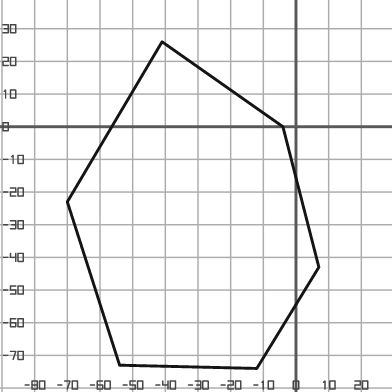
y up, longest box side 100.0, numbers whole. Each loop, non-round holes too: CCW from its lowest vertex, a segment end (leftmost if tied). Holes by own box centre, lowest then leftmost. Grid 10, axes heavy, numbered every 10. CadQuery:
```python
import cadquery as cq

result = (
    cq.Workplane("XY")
    .moveTo(-12.0, -74.0)
    .lineTo(7.0, -43.0)
    .lineTo(-4.0, 0.0)
    .lineTo(-41.0, 26.0)
    .lineTo(-70.0, -23.0)
    .lineTo(-54.0, -73.0)
    .close()
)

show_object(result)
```